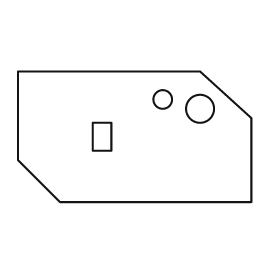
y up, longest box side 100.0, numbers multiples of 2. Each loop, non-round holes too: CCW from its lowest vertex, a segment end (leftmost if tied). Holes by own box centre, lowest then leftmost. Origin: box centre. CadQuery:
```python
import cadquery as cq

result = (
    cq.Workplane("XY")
    .moveTo(-32.0, -28.0)
    .lineTo(50.0, -28.0)
    .lineTo(50.0, 8.0)
    .lineTo(28.0, 28.0)
    .lineTo(-50.0, 28.0)
    .lineTo(-50.0, -10.0)
    .close()
    .moveTo(-18.0, -6.0)
    .lineTo(-10.0, -6.0)
    .lineTo(-10.0, 6.0)
    .lineTo(-18.0, 6.0)
    .close()
    .moveTo(28.0, 12.0)
    .circle(6.0)
    .moveTo(12.0, 16.0)
    .circle(4.0)
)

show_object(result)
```